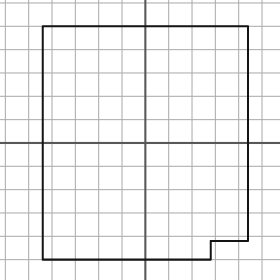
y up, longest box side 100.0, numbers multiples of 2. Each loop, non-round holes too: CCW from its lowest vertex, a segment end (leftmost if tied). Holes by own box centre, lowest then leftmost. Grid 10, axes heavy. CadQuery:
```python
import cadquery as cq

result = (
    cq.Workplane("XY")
    .moveTo(-44.0, -50.0)
    .lineTo(28.0, -50.0)
    .lineTo(28.0, -42.0)
    .lineTo(44.0, -42.0)
    .lineTo(44.0, 50.0)
    .lineTo(-44.0, 50.0)
    .close()
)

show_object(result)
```